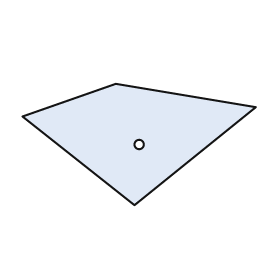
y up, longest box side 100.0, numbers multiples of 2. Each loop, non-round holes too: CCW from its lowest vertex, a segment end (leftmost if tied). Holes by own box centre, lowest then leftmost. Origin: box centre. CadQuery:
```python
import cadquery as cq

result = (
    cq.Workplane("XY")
    .moveTo(-2.0, -26.0)
    .lineTo(50.0, 16.0)
    .lineTo(-10.0, 26.0)
    .lineTo(-50.0, 12.0)
    .close()
    .moveTo(0.0, 0.0)
    .circle(2.0)
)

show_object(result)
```